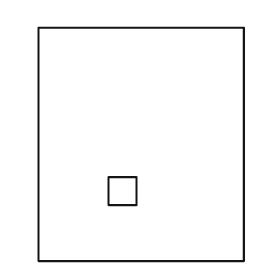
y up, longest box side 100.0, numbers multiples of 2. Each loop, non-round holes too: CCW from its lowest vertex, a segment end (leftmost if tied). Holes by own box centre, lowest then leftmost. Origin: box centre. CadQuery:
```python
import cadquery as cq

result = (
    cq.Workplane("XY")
    .moveTo(-44.0, -50.0)
    .lineTo(44.0, -50.0)
    .lineTo(44.0, 50.0)
    .lineTo(-44.0, 50.0)
    .close()
    .moveTo(-14.0, -26.0)
    .lineTo(-2.0, -26.0)
    .lineTo(-2.0, -14.0)
    .lineTo(-14.0, -14.0)
    .close()
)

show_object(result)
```